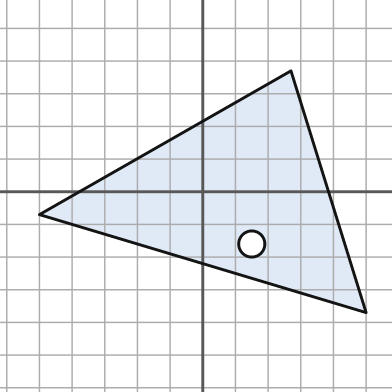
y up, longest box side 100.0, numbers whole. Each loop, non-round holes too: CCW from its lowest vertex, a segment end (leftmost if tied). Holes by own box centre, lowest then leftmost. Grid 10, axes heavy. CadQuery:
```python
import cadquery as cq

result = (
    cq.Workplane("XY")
    .moveTo(50.0, -37.0)
    .lineTo(27.0, 37.0)
    .lineTo(-50.0, -7.0)
    .close()
    .moveTo(15.0, -16.0)
    .circle(4.0)
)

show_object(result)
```